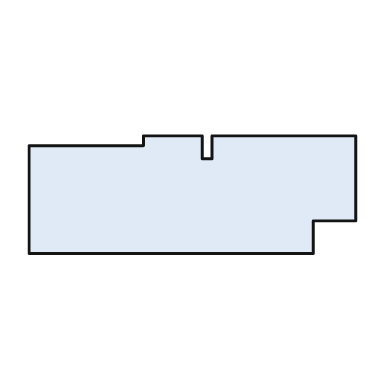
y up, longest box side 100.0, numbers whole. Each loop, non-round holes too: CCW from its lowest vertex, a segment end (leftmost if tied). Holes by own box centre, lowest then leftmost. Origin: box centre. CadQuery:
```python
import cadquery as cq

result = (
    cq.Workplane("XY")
    .moveTo(-50.0, -18.0)
    .lineTo(37.0, -18.0)
    .lineTo(37.0, -8.0)
    .lineTo(50.0, -8.0)
    .lineTo(50.0, 18.0)
    .lineTo(6.0, 18.0)
    .lineTo(6.0, 11.0)
    .lineTo(3.0, 11.0)
    .lineTo(3.0, 18.0)
    .lineTo(-15.0, 18.0)
    .lineTo(-15.0, 15.0)
    .lineTo(-50.0, 15.0)
    .close()
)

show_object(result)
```